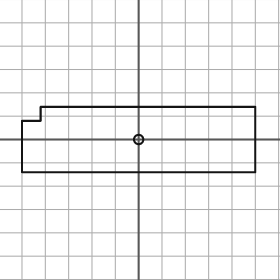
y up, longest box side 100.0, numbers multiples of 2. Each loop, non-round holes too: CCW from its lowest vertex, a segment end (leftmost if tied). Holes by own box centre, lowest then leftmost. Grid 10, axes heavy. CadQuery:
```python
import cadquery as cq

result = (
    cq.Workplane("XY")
    .moveTo(-50.0, -14.0)
    .lineTo(50.0, -14.0)
    .lineTo(50.0, 14.0)
    .lineTo(-42.0, 14.0)
    .lineTo(-42.0, 8.0)
    .lineTo(-50.0, 8.0)
    .close()
    .moveTo(0.0, 0.0)
    .circle(2.0)
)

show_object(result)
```